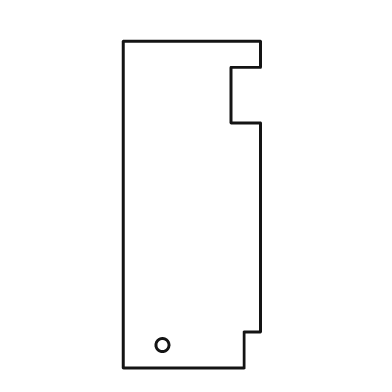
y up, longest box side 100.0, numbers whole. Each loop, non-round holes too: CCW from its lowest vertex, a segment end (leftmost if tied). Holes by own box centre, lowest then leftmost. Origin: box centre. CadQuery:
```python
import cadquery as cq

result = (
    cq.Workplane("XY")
    .moveTo(-21.0, -50.0)
    .lineTo(16.0, -50.0)
    .lineTo(16.0, -39.0)
    .lineTo(21.0, -39.0)
    .lineTo(21.0, 25.0)
    .lineTo(12.0, 25.0)
    .lineTo(12.0, 42.0)
    .lineTo(21.0, 42.0)
    .lineTo(21.0, 50.0)
    .lineTo(-21.0, 50.0)
    .close()
    .moveTo(-9.0, -43.0)
    .circle(2.0)
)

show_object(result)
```